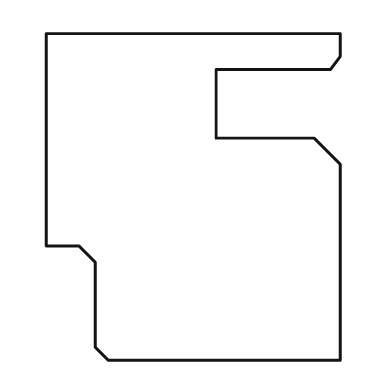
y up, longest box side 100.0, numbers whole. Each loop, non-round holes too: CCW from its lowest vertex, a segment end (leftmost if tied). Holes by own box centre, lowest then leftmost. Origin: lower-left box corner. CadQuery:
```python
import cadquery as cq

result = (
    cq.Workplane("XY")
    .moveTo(19.0, 0.0)
    .lineTo(90.0, 0.0)
    .lineTo(90.0, 60.0)
    .lineTo(82.0, 68.0)
    .lineTo(52.0, 68.0)
    .lineTo(52.0, 89.0)
    .lineTo(87.0, 89.0)
    .lineTo(90.0, 93.0)
    .lineTo(90.0, 100.0)
    .lineTo(0.0, 100.0)
    .lineTo(0.0, 35.0)
    .lineTo(10.0, 35.0)
    .lineTo(15.0, 30.0)
    .lineTo(15.0, 4.0)
    .close()
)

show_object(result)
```